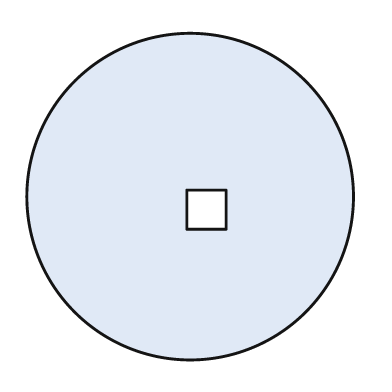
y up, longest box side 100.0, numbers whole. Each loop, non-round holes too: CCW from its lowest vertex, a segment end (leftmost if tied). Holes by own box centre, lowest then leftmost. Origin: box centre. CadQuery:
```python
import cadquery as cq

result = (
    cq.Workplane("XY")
    .moveTo(0.0, 0.0)
    .circle(50.0)
    .moveTo(-1.0, -10.0)
    .lineTo(11.0, -10.0)
    .lineTo(11.0, 2.0)
    .lineTo(-1.0, 2.0)
    .close()
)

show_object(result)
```